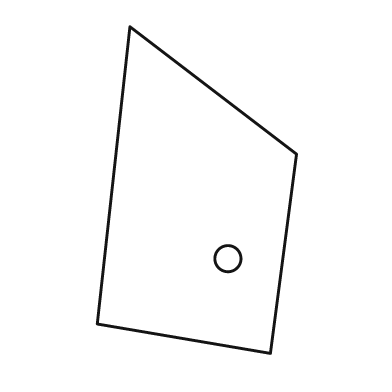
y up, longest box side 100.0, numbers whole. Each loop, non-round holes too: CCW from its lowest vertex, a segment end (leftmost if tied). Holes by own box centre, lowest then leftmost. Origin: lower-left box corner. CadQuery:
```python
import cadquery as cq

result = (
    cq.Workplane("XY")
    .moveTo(53.0, 0.0)
    .lineTo(61.0, 61.0)
    .lineTo(10.0, 100.0)
    .lineTo(0.0, 9.0)
    .close()
    .moveTo(40.0, 29.0)
    .circle(4.0)
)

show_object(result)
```